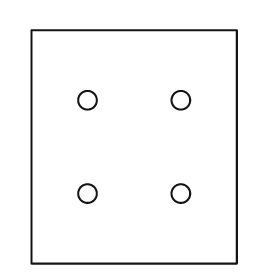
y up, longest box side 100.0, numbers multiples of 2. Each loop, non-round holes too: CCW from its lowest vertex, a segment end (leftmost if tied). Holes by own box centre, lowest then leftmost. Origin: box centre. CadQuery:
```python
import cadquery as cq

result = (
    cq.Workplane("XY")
    .moveTo(-44.0, -50.0)
    .lineTo(44.0, -50.0)
    .lineTo(44.0, 50.0)
    .lineTo(-44.0, 50.0)
    .close()
    .moveTo(-20.0, -20.0)
    .circle(4.0)
    .moveTo(20.0, -20.0)
    .circle(4.0)
    .moveTo(-20.0, 20.0)
    .circle(4.0)
    .moveTo(20.0, 20.0)
    .circle(4.0)
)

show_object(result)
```